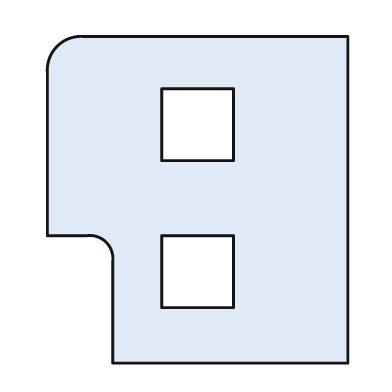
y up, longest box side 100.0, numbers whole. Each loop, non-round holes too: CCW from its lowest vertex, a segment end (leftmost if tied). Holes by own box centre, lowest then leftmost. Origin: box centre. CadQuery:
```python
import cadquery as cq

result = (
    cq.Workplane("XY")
    .moveTo(-26.0, -50.0)
    .lineTo(46.0, -50.0)
    .lineTo(46.0, 50.0)
    .lineTo(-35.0, 50.0)
    .threePointArc((-43.0, 47.0), (-46.0, 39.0))
    .lineTo(-46.0, -11.0)
    .lineTo(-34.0, -11.0)
    .threePointArc((-28.0, -13.0), (-26.0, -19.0))
    .close()
    .moveTo(-11.0, -33.0)
    .lineTo(11.0, -33.0)
    .lineTo(11.0, -11.0)
    .lineTo(-11.0, -11.0)
    .close()
    .moveTo(-11.0, 12.0)
    .lineTo(11.0, 12.0)
    .lineTo(11.0, 34.0)
    .lineTo(-11.0, 34.0)
    .close()
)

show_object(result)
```